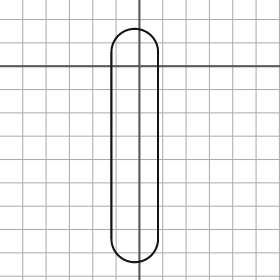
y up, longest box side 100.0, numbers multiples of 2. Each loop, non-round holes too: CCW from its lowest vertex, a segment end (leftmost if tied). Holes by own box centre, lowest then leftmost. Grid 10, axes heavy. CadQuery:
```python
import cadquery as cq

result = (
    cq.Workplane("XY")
    .moveTo(-12.0, -74.0)
    .threePointArc((-2.0, -84.0), (8.0, -74.0))
    .lineTo(8.0, 6.0)
    .threePointArc((-2.0, 16.0), (-12.0, 6.0))
    .close()
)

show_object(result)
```